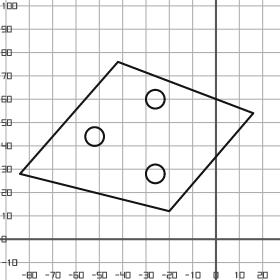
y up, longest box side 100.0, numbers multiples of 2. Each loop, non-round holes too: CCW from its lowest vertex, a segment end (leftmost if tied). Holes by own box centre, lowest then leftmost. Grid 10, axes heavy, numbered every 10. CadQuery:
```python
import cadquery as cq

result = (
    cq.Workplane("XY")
    .moveTo(-20.0, 12.0)
    .lineTo(16.0, 54.0)
    .lineTo(-42.0, 76.0)
    .lineTo(-84.0, 28.0)
    .close()
    .moveTo(-26.0, 28.0)
    .circle(4.0)
    .moveTo(-52.0, 44.0)
    .circle(4.0)
    .moveTo(-26.0, 60.0)
    .circle(4.0)
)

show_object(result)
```